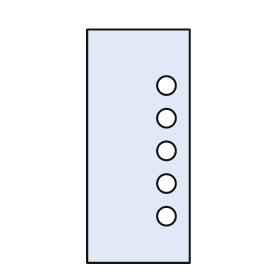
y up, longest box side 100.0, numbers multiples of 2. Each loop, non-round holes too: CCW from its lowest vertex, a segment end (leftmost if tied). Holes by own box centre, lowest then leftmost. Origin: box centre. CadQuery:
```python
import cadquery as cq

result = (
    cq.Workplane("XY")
    .moveTo(-22.0, -50.0)
    .lineTo(22.0, -50.0)
    .lineTo(22.0, 50.0)
    .lineTo(-22.0, 50.0)
    .close()
    .moveTo(12.0, -30.0)
    .circle(4.0)
    .moveTo(12.0, -16.0)
    .circle(4.0)
    .moveTo(12.0, -2.0)
    .circle(4.0)
    .moveTo(12.0, 12.0)
    .circle(4.0)
    .moveTo(12.0, 26.0)
    .circle(4.0)
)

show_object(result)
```